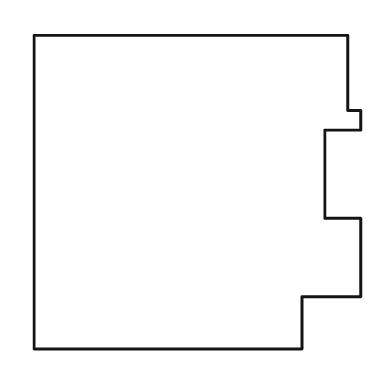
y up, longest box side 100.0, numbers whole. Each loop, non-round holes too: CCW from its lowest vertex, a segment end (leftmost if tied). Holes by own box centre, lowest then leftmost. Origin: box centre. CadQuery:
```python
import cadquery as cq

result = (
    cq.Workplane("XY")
    .moveTo(-50.0, -48.0)
    .lineTo(32.0, -48.0)
    .lineTo(32.0, -32.0)
    .lineTo(50.0, -32.0)
    .lineTo(50.0, -8.0)
    .lineTo(39.0, -8.0)
    .lineTo(39.0, 19.0)
    .lineTo(50.0, 19.0)
    .lineTo(50.0, 25.0)
    .lineTo(46.0, 25.0)
    .lineTo(46.0, 48.0)
    .lineTo(-50.0, 48.0)
    .close()
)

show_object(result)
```